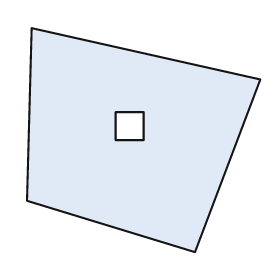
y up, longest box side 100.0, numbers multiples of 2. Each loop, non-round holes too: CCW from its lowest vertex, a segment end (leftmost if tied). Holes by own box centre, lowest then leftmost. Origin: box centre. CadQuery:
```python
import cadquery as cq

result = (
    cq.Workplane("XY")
    .moveTo(22.0, -48.0)
    .lineTo(50.0, 26.0)
    .lineTo(-48.0, 48.0)
    .lineTo(-50.0, -26.0)
    .close()
    .moveTo(-12.0, 0.0)
    .lineTo(0.0, 0.0)
    .lineTo(0.0, 12.0)
    .lineTo(-12.0, 12.0)
    .close()
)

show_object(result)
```